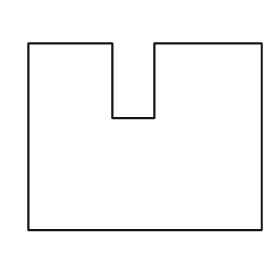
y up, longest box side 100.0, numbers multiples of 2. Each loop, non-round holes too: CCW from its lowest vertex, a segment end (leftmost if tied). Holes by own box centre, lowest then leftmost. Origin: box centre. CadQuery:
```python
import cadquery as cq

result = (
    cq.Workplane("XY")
    .moveTo(-50.0, -40.0)
    .lineTo(50.0, -40.0)
    .lineTo(50.0, 40.0)
    .lineTo(4.0, 40.0)
    .lineTo(4.0, 8.0)
    .lineTo(-14.0, 8.0)
    .lineTo(-14.0, 40.0)
    .lineTo(-50.0, 40.0)
    .close()
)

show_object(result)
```